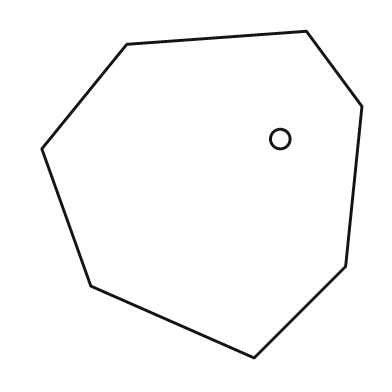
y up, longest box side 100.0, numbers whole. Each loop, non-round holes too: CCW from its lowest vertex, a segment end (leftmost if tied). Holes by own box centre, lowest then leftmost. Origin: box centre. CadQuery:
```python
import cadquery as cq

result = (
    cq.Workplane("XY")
    .moveTo(16.0, -50.0)
    .lineTo(44.0, -22.0)
    .lineTo(49.0, 27.0)
    .lineTo(32.0, 50.0)
    .lineTo(-23.0, 46.0)
    .lineTo(-49.0, 14.0)
    .lineTo(-34.0, -28.0)
    .close()
    .moveTo(24.0, 17.0)
    .circle(3.0)
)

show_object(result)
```